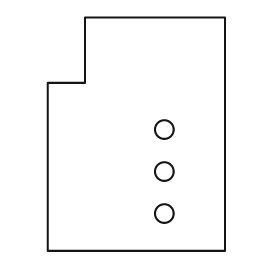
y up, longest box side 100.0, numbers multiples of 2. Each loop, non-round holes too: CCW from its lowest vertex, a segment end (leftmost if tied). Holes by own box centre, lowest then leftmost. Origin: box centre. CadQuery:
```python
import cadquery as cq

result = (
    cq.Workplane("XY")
    .moveTo(-38.0, -50.0)
    .lineTo(38.0, -50.0)
    .lineTo(38.0, 50.0)
    .lineTo(-22.0, 50.0)
    .lineTo(-22.0, 22.0)
    .lineTo(-38.0, 22.0)
    .close()
    .moveTo(12.0, -34.0)
    .circle(4.0)
    .moveTo(12.0, -16.0)
    .circle(4.0)
    .moveTo(12.0, 2.0)
    .circle(4.0)
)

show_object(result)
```